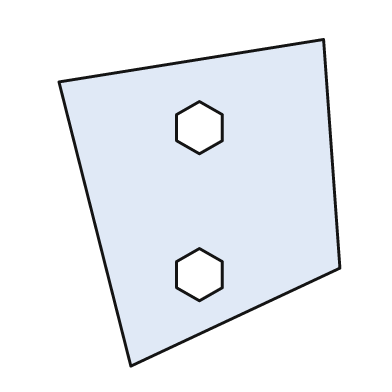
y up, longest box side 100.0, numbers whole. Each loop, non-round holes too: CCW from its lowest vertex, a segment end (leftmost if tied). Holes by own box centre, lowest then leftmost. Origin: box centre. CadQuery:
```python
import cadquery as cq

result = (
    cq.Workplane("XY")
    .moveTo(-21.0, -50.0)
    .lineTo(43.0, -20.0)
    .lineTo(38.0, 50.0)
    .lineTo(-43.0, 37.0)
    .close()
    .moveTo(0.0, -30.0)
    .lineTo(7.0, -26.0)
    .lineTo(7.0, -18.0)
    .lineTo(0.0, -14.0)
    .lineTo(-7.0, -18.0)
    .lineTo(-7.0, -26.0)
    .close()
    .moveTo(0.0, 15.0)
    .lineTo(7.0, 19.0)
    .lineTo(7.0, 27.0)
    .lineTo(0.0, 31.0)
    .lineTo(-7.0, 27.0)
    .lineTo(-7.0, 19.0)
    .close()
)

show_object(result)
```